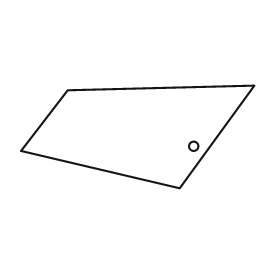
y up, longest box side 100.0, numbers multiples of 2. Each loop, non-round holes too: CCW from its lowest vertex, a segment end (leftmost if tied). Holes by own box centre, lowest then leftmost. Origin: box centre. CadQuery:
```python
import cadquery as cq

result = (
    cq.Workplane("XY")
    .moveTo(18.0, -22.0)
    .lineTo(50.0, 22.0)
    .lineTo(-30.0, 20.0)
    .lineTo(-50.0, -6.0)
    .close()
    .moveTo(24.0, -4.0)
    .circle(2.0)
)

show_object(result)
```